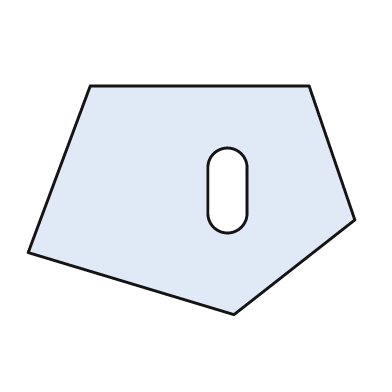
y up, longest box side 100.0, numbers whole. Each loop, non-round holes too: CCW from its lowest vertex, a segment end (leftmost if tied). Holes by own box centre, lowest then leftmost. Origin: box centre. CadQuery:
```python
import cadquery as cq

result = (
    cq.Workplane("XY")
    .moveTo(13.0, -35.0)
    .lineTo(50.0, -6.0)
    .lineTo(36.0, 35.0)
    .lineTo(-31.0, 35.0)
    .lineTo(-50.0, -16.0)
    .close()
    .moveTo(5.0, -4.0)
    .threePointArc((11.0, -10.0), (17.0, -4.0))
    .lineTo(17.0, 10.0)
    .threePointArc((11.0, 16.0), (5.0, 10.0))
    .close()
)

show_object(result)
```